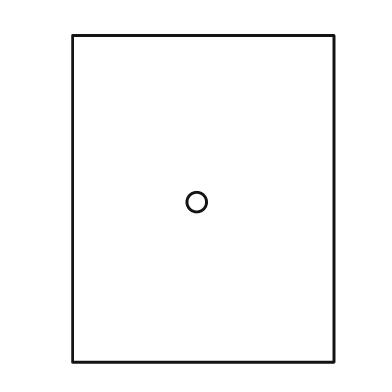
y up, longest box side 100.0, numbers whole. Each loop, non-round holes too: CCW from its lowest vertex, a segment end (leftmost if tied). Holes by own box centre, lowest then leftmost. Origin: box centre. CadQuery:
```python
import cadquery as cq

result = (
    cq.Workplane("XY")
    .moveTo(-40.0, -50.0)
    .lineTo(40.0, -50.0)
    .lineTo(40.0, 50.0)
    .lineTo(-40.0, 50.0)
    .close()
    .moveTo(-2.0, -1.0)
    .circle(3.0)
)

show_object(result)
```